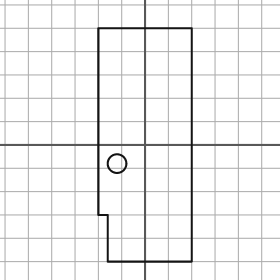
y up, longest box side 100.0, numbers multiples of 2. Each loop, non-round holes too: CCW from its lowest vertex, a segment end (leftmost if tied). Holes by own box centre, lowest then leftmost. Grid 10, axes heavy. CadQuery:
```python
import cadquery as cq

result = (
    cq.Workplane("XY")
    .moveTo(-16.0, -50.0)
    .lineTo(20.0, -50.0)
    .lineTo(20.0, 50.0)
    .lineTo(-20.0, 50.0)
    .lineTo(-20.0, -30.0)
    .lineTo(-16.0, -30.0)
    .close()
    .moveTo(-12.0, -8.0)
    .circle(4.0)
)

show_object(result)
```